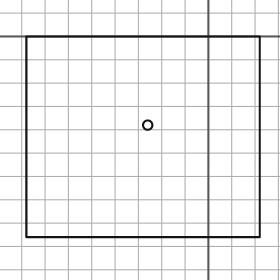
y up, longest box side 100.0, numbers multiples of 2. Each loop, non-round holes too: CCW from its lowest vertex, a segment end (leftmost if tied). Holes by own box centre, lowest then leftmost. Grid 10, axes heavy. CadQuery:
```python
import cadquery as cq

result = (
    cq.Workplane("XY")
    .moveTo(-78.0, -86.0)
    .lineTo(22.0, -86.0)
    .lineTo(22.0, 0.0)
    .lineTo(-78.0, 0.0)
    .close()
    .moveTo(-26.0, -38.0)
    .circle(2.0)
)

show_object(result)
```